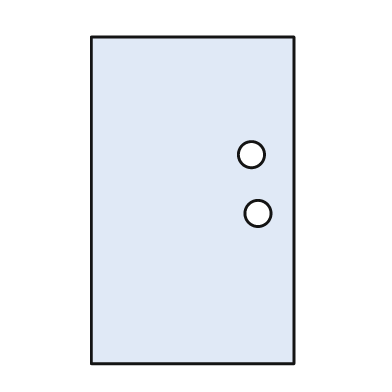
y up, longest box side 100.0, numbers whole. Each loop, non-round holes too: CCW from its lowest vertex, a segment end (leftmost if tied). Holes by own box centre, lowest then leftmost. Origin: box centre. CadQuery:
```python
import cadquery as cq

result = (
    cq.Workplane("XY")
    .moveTo(-31.0, -50.0)
    .lineTo(31.0, -50.0)
    .lineTo(31.0, 50.0)
    .lineTo(-31.0, 50.0)
    .close()
    .moveTo(20.0, -4.0)
    .circle(4.0)
    .moveTo(18.0, 14.0)
    .circle(4.0)
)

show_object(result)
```